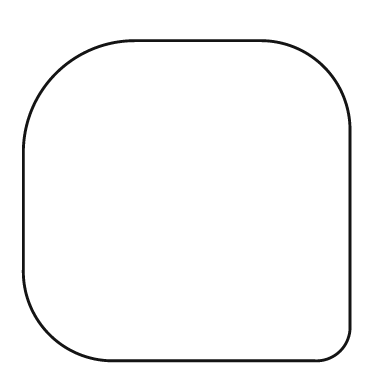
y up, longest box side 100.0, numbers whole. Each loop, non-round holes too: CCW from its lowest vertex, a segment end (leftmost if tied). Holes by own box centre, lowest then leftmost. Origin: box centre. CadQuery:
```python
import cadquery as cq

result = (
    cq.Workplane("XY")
    .moveTo(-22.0, -49.0)
    .lineTo(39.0, -49.0)
    .threePointArc((47.0, -46.0), (50.0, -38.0))
    .lineTo(50.0, 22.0)
    .threePointArc((42.0, 41.0), (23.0, 49.0))
    .lineTo(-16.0, 49.0)
    .threePointArc((-40.0, 39.0), (-50.0, 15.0))
    .lineTo(-50.0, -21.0)
    .threePointArc((-42.0, -41.0), (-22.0, -49.0))
    .close()
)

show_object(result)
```